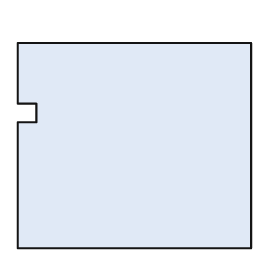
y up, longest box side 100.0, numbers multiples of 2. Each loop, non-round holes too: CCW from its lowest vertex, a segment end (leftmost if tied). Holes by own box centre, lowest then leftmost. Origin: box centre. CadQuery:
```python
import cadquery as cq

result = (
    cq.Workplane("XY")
    .moveTo(-50.0, -44.0)
    .lineTo(50.0, -44.0)
    .lineTo(50.0, 44.0)
    .lineTo(-50.0, 44.0)
    .lineTo(-50.0, 18.0)
    .lineTo(-42.0, 18.0)
    .lineTo(-42.0, 10.0)
    .lineTo(-50.0, 10.0)
    .close()
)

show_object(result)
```